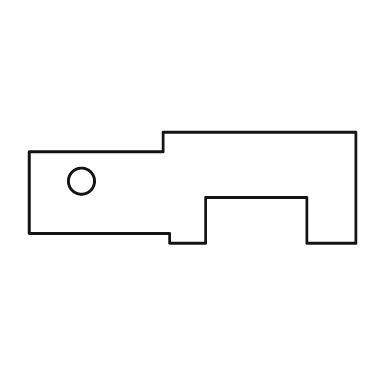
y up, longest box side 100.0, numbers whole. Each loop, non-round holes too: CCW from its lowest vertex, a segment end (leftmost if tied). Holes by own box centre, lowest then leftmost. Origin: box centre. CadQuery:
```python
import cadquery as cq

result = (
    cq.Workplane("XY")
    .moveTo(-7.0, -17.0)
    .lineTo(4.0, -17.0)
    .lineTo(4.0, -3.0)
    .lineTo(35.0, -3.0)
    .lineTo(35.0, -17.0)
    .lineTo(50.0, -17.0)
    .lineTo(50.0, 17.0)
    .lineTo(-9.0, 17.0)
    .lineTo(-9.0, 11.0)
    .lineTo(-50.0, 11.0)
    .lineTo(-50.0, -14.0)
    .lineTo(-7.0, -14.0)
    .close()
    .moveTo(-34.0, 2.0)
    .circle(4.0)
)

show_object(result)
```